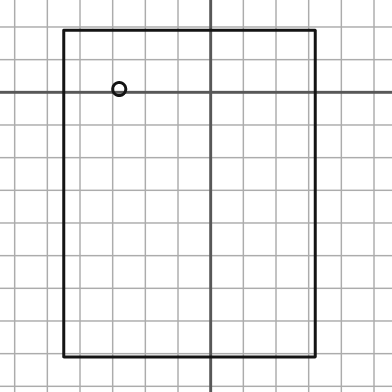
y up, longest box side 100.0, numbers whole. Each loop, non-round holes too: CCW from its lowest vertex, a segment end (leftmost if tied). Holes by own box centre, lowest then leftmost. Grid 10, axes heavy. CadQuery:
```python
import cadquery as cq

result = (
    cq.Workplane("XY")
    .moveTo(-45.0, -81.0)
    .lineTo(32.0, -81.0)
    .lineTo(32.0, 19.0)
    .lineTo(-45.0, 19.0)
    .close()
    .moveTo(-28.0, 1.0)
    .circle(2.0)
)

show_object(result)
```